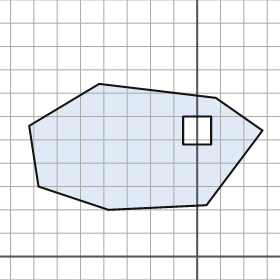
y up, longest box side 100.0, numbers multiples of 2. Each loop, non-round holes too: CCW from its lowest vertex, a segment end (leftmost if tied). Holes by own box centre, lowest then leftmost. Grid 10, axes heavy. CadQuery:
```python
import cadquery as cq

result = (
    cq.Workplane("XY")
    .moveTo(-38.0, 20.0)
    .lineTo(4.0, 22.0)
    .lineTo(28.0, 54.0)
    .lineTo(8.0, 68.0)
    .lineTo(-42.0, 74.0)
    .lineTo(-72.0, 56.0)
    .lineTo(-68.0, 30.0)
    .close()
    .moveTo(-6.0, 48.0)
    .lineTo(6.0, 48.0)
    .lineTo(6.0, 60.0)
    .lineTo(-6.0, 60.0)
    .close()
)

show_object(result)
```